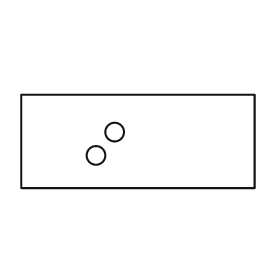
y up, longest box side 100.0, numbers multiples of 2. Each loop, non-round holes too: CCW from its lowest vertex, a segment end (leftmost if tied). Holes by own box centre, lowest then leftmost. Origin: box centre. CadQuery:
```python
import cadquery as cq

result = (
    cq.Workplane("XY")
    .moveTo(-50.0, -20.0)
    .lineTo(50.0, -20.0)
    .lineTo(50.0, 20.0)
    .lineTo(-50.0, 20.0)
    .close()
    .moveTo(-18.0, -6.0)
    .circle(4.0)
    .moveTo(-10.0, 4.0)
    .circle(4.0)
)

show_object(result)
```